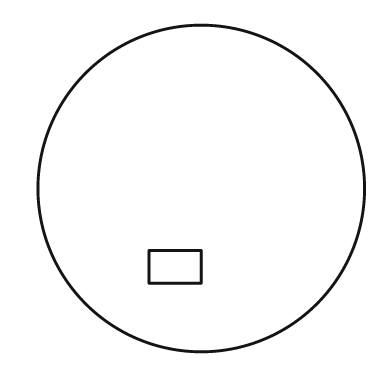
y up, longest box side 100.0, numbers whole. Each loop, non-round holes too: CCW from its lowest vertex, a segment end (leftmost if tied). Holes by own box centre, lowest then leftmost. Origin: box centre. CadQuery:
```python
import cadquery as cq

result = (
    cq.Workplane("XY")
    .moveTo(0.0, 0.0)
    .circle(50.0)
    .moveTo(-16.0, -29.0)
    .lineTo(0.0, -29.0)
    .lineTo(0.0, -19.0)
    .lineTo(-16.0, -19.0)
    .close()
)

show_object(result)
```